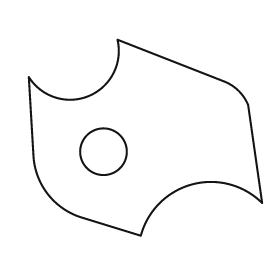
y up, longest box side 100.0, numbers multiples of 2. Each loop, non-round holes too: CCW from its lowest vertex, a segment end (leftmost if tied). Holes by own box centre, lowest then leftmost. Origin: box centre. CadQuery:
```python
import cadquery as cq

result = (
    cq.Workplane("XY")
    .moveTo(-2.0, -42.0)
    .threePointArc((20.0, -20.0), (50.0, -28.0))
    .lineTo(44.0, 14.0)
    .threePointArc((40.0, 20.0), (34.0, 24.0))
    .lineTo(-12.0, 42.0)
    .threePointArc((-24.0, 18.0), (-50.0, 26.0))
    .lineTo(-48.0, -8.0)
    .threePointArc((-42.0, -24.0), (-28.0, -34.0))
    .close()
    .moveTo(-18.0, -6.0)
    .circle(10.0)
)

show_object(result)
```